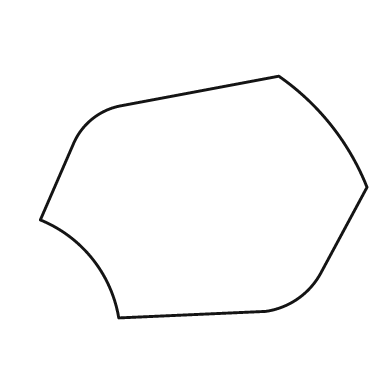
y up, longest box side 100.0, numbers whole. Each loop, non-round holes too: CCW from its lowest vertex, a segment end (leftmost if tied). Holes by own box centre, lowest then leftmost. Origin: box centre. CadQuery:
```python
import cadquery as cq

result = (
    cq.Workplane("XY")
    .moveTo(-26.0, -37.0)
    .lineTo(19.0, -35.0)
    .threePointArc((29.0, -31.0), (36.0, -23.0))
    .lineTo(50.0, 3.0)
    .threePointArc((39.0, 22.0), (23.0, 37.0))
    .lineTo(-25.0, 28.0)
    .threePointArc((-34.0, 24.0), (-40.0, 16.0))
    .lineTo(-50.0, -7.0)
    .threePointArc((-34.0, -19.0), (-26.0, -37.0))
    .close()
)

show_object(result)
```